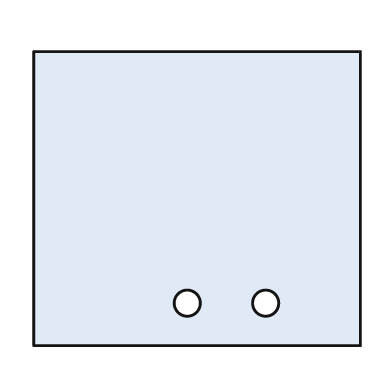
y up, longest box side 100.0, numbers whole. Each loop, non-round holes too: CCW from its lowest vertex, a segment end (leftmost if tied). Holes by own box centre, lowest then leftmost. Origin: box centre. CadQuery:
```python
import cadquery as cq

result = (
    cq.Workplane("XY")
    .moveTo(-50.0, -45.0)
    .lineTo(50.0, -45.0)
    .lineTo(50.0, 45.0)
    .lineTo(-50.0, 45.0)
    .close()
    .moveTo(-3.0, -32.0)
    .circle(4.0)
    .moveTo(21.0, -32.0)
    .circle(4.0)
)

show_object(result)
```